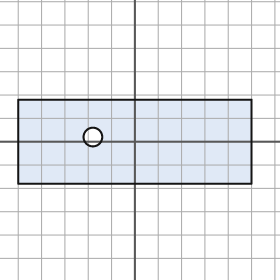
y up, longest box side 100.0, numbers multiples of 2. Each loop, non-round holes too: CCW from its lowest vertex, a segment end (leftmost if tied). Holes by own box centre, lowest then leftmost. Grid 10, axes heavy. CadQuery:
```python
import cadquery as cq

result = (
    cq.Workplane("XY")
    .moveTo(-50.0, -18.0)
    .lineTo(50.0, -18.0)
    .lineTo(50.0, 18.0)
    .lineTo(-50.0, 18.0)
    .close()
    .moveTo(-18.0, 2.0)
    .circle(4.0)
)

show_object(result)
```